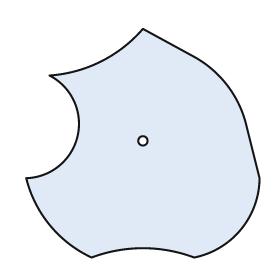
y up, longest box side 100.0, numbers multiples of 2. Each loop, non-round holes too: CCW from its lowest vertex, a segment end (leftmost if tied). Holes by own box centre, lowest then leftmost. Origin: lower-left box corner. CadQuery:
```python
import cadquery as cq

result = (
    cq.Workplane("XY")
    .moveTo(28.0, 0.0)
    .threePointArc((50.0, 4.0), (72.0, 0.0))
    .threePointArc((92.0, 12.0), (100.0, 34.0))
    .lineTo(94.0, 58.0)
    .threePointArc((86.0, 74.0), (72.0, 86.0))
    .lineTo(50.0, 98.0)
    .threePointArc((32.0, 84.0), (10.0, 78.0))
    .threePointArc((22.0, 52.0), (0.0, 34.0))
    .threePointArc((10.0, 14.0), (28.0, 0.0))
    .close()
    .moveTo(50.0, 50.0)
    .circle(2.0)
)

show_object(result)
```